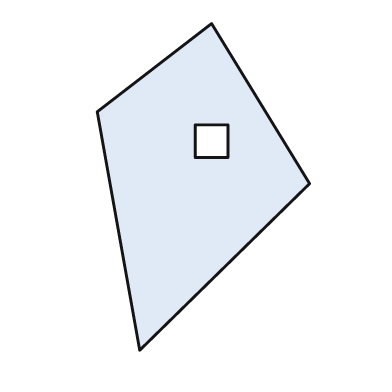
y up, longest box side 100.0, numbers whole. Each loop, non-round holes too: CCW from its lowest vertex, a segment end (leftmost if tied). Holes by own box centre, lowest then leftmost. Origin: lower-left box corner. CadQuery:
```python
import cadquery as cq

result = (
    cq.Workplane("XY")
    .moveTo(13.0, 0.0)
    .lineTo(65.0, 51.0)
    .lineTo(35.0, 100.0)
    .lineTo(0.0, 73.0)
    .close()
    .moveTo(30.0, 59.0)
    .lineTo(40.0, 59.0)
    .lineTo(40.0, 69.0)
    .lineTo(30.0, 69.0)
    .close()
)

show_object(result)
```